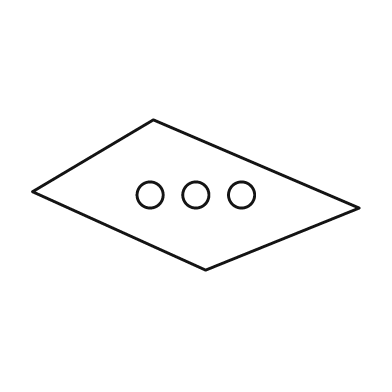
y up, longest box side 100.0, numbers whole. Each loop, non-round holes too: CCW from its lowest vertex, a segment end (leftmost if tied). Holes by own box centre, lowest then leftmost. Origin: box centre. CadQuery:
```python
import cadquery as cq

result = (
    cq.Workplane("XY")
    .moveTo(3.0, -23.0)
    .lineTo(50.0, -4.0)
    .lineTo(-13.0, 23.0)
    .lineTo(-50.0, 1.0)
    .close()
    .moveTo(-14.0, 0.0)
    .circle(4.0)
    .moveTo(0.0, 0.0)
    .circle(4.0)
    .moveTo(14.0, 0.0)
    .circle(4.0)
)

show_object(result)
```